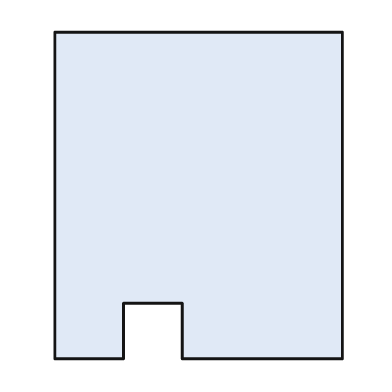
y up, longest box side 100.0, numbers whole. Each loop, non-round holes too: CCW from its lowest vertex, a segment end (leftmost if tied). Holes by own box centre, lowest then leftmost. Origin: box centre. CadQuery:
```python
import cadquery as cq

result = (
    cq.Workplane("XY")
    .moveTo(-44.0, -50.0)
    .lineTo(-23.0, -50.0)
    .lineTo(-23.0, -33.0)
    .lineTo(-5.0, -33.0)
    .lineTo(-5.0, -50.0)
    .lineTo(44.0, -50.0)
    .lineTo(44.0, 50.0)
    .lineTo(-44.0, 50.0)
    .close()
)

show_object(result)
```